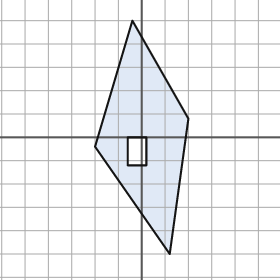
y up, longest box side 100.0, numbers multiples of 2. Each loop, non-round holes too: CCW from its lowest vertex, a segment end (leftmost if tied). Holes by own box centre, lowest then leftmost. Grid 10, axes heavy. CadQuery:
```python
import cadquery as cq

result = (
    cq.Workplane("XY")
    .moveTo(12.0, -50.0)
    .lineTo(20.0, 8.0)
    .lineTo(-4.0, 50.0)
    .lineTo(-20.0, -4.0)
    .close()
    .moveTo(-6.0, -12.0)
    .lineTo(2.0, -12.0)
    .lineTo(2.0, 0.0)
    .lineTo(-6.0, 0.0)
    .close()
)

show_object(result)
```